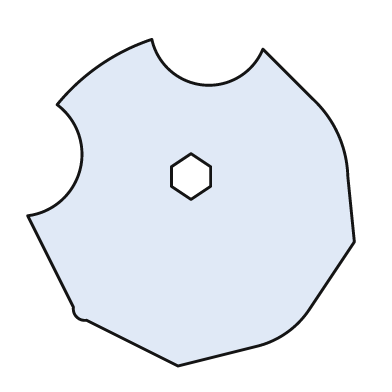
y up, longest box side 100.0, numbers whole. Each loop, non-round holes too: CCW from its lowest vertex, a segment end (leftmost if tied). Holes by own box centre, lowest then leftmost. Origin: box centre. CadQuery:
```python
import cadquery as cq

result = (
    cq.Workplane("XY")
    .moveTo(-4.0, -50.0)
    .lineTo(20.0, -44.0)
    .threePointArc((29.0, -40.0), (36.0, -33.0))
    .lineTo(50.0, -12.0)
    .lineTo(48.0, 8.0)
    .threePointArc((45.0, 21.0), (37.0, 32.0))
    .lineTo(22.0, 47.0)
    .threePointArc((4.0, 36.0), (-12.0, 50.0))
    .threePointArc((-28.0, 42.0), (-41.0, 30.0))
    .threePointArc((-34.0, 10.0), (-50.0, -4.0))
    .lineTo(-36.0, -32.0)
    .threePointArc((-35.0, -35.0), (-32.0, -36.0))
    .close()
    .moveTo(0.0, 1.0)
    .lineTo(6.0, 5.0)
    .lineTo(6.0, 11.0)
    .lineTo(0.0, 15.0)
    .lineTo(-6.0, 11.0)
    .lineTo(-6.0, 5.0)
    .close()
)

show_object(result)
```